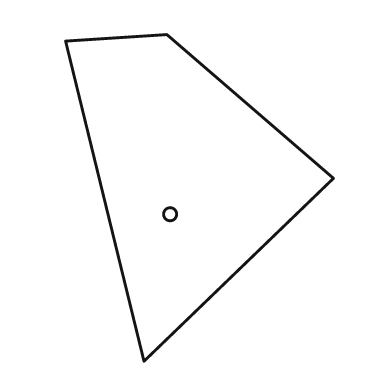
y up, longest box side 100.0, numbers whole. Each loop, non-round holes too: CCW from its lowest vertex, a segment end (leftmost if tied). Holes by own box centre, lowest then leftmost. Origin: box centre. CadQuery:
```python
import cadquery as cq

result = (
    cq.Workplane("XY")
    .moveTo(-17.0, -50.0)
    .lineTo(41.0, 6.0)
    .lineTo(-10.0, 50.0)
    .lineTo(-41.0, 48.0)
    .close()
    .moveTo(-9.0, -5.0)
    .circle(2.0)
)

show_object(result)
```